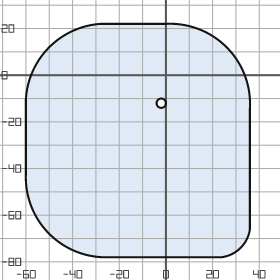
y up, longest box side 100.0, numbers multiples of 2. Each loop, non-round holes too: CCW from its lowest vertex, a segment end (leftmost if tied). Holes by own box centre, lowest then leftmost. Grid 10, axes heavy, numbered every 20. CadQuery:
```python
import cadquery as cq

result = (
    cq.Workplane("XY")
    .moveTo(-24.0, -78.0)
    .lineTo(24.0, -78.0)
    .threePointArc((32.0, -74.0), (36.0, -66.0))
    .lineTo(36.0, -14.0)
    .threePointArc((26.0, 12.0), (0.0, 22.0))
    .lineTo(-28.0, 22.0)
    .threePointArc((-50.0, 12.0), (-60.0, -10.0))
    .lineTo(-60.0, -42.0)
    .threePointArc((-50.0, -68.0), (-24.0, -78.0))
    .close()
    .moveTo(-2.0, -12.0)
    .circle(2.0)
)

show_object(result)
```